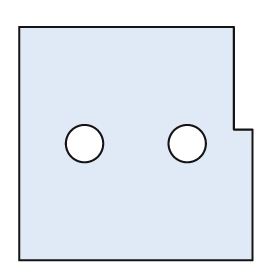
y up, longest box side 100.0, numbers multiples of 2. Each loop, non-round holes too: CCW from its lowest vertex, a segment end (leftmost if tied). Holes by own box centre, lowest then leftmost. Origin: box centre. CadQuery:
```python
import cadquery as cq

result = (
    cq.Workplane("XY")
    .moveTo(-50.0, -50.0)
    .lineTo(50.0, -50.0)
    .lineTo(50.0, 6.0)
    .lineTo(42.0, 6.0)
    .lineTo(42.0, 50.0)
    .lineTo(-50.0, 50.0)
    .close()
    .moveTo(-22.0, 0.0)
    .circle(8.0)
    .moveTo(22.0, 0.0)
    .circle(8.0)
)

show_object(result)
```